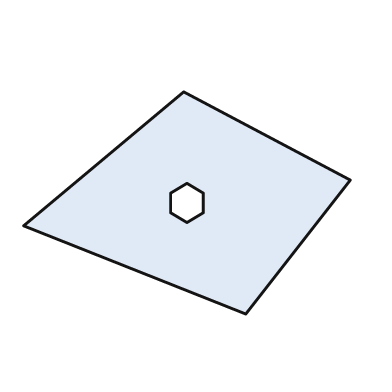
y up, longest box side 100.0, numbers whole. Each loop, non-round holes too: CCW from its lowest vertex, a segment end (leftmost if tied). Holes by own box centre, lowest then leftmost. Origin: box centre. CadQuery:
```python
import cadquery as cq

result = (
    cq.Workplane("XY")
    .moveTo(18.0, -34.0)
    .lineTo(50.0, 7.0)
    .lineTo(-1.0, 34.0)
    .lineTo(-50.0, -7.0)
    .close()
    .moveTo(0.0, -6.0)
    .lineTo(5.0, -3.0)
    .lineTo(5.0, 3.0)
    .lineTo(0.0, 6.0)
    .lineTo(-5.0, 3.0)
    .lineTo(-5.0, -3.0)
    .close()
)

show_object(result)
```